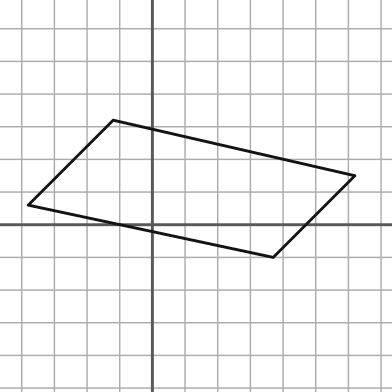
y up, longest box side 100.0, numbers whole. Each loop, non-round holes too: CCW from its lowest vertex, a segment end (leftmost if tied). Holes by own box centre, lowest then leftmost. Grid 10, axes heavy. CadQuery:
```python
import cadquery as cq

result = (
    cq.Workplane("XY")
    .moveTo(37.0, -10.0)
    .lineTo(62.0, 15.0)
    .lineTo(-12.0, 32.0)
    .lineTo(-38.0, 6.0)
    .close()
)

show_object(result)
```